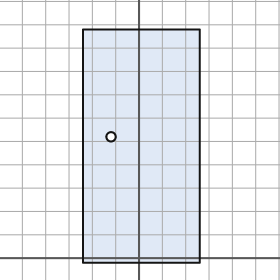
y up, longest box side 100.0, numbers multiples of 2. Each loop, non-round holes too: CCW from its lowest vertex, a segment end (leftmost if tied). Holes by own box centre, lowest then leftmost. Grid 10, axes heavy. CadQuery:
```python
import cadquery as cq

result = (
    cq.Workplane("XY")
    .moveTo(-24.0, -2.0)
    .lineTo(26.0, -2.0)
    .lineTo(26.0, 98.0)
    .lineTo(-24.0, 98.0)
    .close()
    .moveTo(-12.0, 52.0)
    .circle(2.0)
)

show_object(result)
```